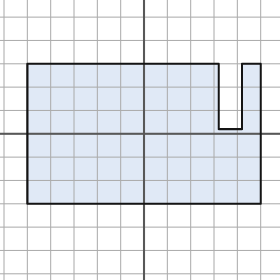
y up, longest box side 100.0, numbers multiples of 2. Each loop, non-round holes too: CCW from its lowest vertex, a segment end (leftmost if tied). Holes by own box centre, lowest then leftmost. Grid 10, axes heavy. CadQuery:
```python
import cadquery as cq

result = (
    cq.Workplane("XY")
    .moveTo(-50.0, -30.0)
    .lineTo(50.0, -30.0)
    .lineTo(50.0, 30.0)
    .lineTo(42.0, 30.0)
    .lineTo(42.0, 2.0)
    .lineTo(32.0, 2.0)
    .lineTo(32.0, 30.0)
    .lineTo(-50.0, 30.0)
    .close()
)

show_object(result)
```